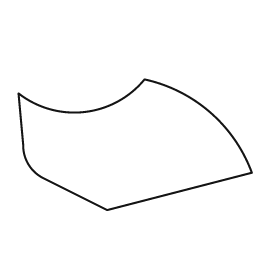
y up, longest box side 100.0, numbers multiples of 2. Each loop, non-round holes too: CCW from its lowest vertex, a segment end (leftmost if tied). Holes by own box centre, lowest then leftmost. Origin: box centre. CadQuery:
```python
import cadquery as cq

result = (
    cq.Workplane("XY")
    .moveTo(-12.0, -28.0)
    .lineTo(50.0, -12.0)
    .threePointArc((32.0, 14.0), (4.0, 28.0))
    .threePointArc((-22.0, 14.0), (-50.0, 22.0))
    .lineTo(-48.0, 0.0)
    .threePointArc((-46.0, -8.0), (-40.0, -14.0))
    .close()
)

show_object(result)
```